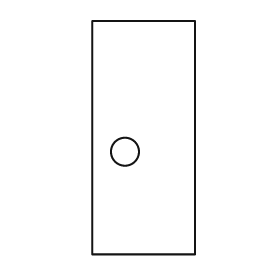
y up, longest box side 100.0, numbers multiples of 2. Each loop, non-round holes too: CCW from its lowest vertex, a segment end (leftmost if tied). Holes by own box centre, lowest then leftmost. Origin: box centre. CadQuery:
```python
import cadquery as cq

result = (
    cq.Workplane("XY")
    .moveTo(-22.0, -50.0)
    .lineTo(22.0, -50.0)
    .lineTo(22.0, 50.0)
    .lineTo(-22.0, 50.0)
    .close()
    .moveTo(-8.0, -6.0)
    .circle(6.0)
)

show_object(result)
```